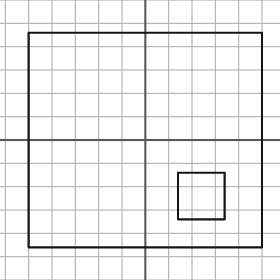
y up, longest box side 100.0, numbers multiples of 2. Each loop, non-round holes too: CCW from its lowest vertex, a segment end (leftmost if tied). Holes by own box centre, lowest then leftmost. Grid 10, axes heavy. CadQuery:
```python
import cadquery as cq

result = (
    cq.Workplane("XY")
    .moveTo(-50.0, -46.0)
    .lineTo(50.0, -46.0)
    .lineTo(50.0, 46.0)
    .lineTo(-50.0, 46.0)
    .close()
    .moveTo(14.0, -34.0)
    .lineTo(34.0, -34.0)
    .lineTo(34.0, -14.0)
    .lineTo(14.0, -14.0)
    .close()
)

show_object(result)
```